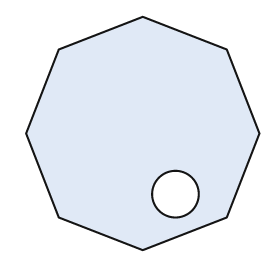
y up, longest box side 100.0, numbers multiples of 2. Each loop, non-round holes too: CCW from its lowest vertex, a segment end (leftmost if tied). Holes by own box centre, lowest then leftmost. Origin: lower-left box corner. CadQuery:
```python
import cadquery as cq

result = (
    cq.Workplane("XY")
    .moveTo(50.0, 0.0)
    .lineTo(86.0, 14.0)
    .lineTo(100.0, 50.0)
    .lineTo(86.0, 86.0)
    .lineTo(50.0, 100.0)
    .lineTo(14.0, 86.0)
    .lineTo(0.0, 50.0)
    .lineTo(14.0, 14.0)
    .close()
    .moveTo(64.0, 24.0)
    .circle(10.0)
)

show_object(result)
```